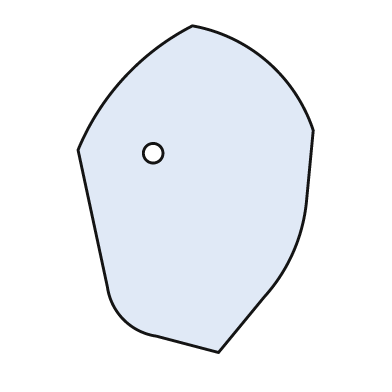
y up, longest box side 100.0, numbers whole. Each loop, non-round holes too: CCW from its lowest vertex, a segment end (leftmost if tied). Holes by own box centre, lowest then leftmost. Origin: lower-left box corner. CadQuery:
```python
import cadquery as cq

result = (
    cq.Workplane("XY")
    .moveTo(43.0, 0.0)
    .lineTo(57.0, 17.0)
    .threePointArc((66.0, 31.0), (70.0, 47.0))
    .lineTo(72.0, 68.0)
    .threePointArc((58.0, 89.0), (35.0, 100.0))
    .threePointArc((14.0, 84.0), (0.0, 62.0))
    .lineTo(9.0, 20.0)
    .threePointArc((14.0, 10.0), (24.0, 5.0))
    .close()
    .moveTo(23.0, 61.0)
    .circle(3.0)
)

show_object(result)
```